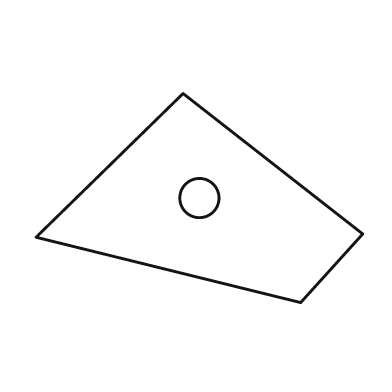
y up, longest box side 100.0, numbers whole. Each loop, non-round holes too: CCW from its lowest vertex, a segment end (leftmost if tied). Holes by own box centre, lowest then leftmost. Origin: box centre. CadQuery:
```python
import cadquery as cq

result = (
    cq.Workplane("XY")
    .moveTo(31.0, -32.0)
    .lineTo(50.0, -11.0)
    .lineTo(-5.0, 32.0)
    .lineTo(-50.0, -12.0)
    .close()
    .moveTo(0.0, 0.0)
    .circle(6.0)
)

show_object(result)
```